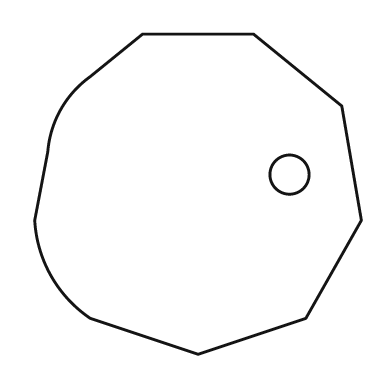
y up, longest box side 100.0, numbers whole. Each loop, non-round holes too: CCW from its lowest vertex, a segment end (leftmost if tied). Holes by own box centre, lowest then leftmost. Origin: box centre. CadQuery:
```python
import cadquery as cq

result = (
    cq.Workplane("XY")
    .moveTo(0.0, -49.0)
    .lineTo(33.0, -38.0)
    .lineTo(50.0, -8.0)
    .lineTo(44.0, 27.0)
    .lineTo(17.0, 49.0)
    .lineTo(-17.0, 49.0)
    .lineTo(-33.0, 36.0)
    .threePointArc((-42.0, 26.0), (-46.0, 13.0))
    .lineTo(-50.0, -8.0)
    .threePointArc((-45.0, -25.0), (-33.0, -38.0))
    .close()
    .moveTo(28.0, 6.0)
    .circle(6.0)
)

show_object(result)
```